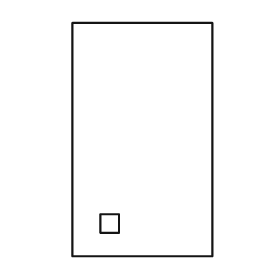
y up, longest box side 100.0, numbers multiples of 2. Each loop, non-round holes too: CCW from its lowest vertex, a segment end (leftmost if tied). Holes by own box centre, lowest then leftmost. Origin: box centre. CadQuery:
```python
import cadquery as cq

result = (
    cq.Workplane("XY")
    .moveTo(-30.0, -50.0)
    .lineTo(30.0, -50.0)
    .lineTo(30.0, 50.0)
    .lineTo(-30.0, 50.0)
    .close()
    .moveTo(-18.0, -40.0)
    .lineTo(-10.0, -40.0)
    .lineTo(-10.0, -32.0)
    .lineTo(-18.0, -32.0)
    .close()
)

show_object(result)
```